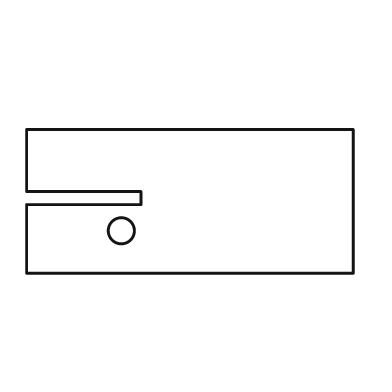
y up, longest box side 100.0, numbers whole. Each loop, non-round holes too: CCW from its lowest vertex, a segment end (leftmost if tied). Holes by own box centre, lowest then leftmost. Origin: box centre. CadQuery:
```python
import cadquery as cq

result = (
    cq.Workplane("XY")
    .moveTo(-50.0, -22.0)
    .lineTo(50.0, -22.0)
    .lineTo(50.0, 22.0)
    .lineTo(-50.0, 22.0)
    .lineTo(-50.0, 3.0)
    .lineTo(-15.0, 3.0)
    .lineTo(-15.0, -1.0)
    .lineTo(-50.0, -1.0)
    .close()
    .moveTo(-21.0, -9.0)
    .circle(4.0)
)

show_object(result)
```